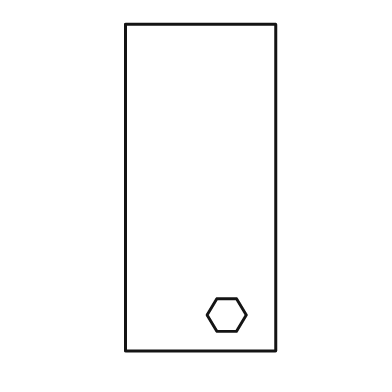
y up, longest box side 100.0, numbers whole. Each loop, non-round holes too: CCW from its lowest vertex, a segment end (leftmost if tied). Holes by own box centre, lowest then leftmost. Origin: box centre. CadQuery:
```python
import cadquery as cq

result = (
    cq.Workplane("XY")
    .moveTo(-23.0, -50.0)
    .lineTo(23.0, -50.0)
    .lineTo(23.0, 50.0)
    .lineTo(-23.0, 50.0)
    .close()
    .moveTo(5.0, -44.0)
    .lineTo(11.0, -44.0)
    .lineTo(14.0, -39.0)
    .lineTo(11.0, -34.0)
    .lineTo(5.0, -34.0)
    .lineTo(2.0, -39.0)
    .close()
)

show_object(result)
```